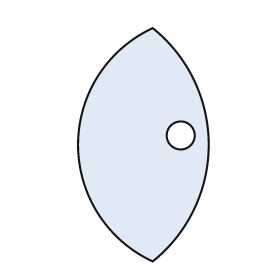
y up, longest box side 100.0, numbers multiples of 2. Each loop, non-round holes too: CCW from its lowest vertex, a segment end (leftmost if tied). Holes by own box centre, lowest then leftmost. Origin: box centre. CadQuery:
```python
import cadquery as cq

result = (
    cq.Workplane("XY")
    .moveTo(4.0, -50.0)
    .threePointArc((28.0, 0.0), (4.0, 50.0))
    .threePointArc((-28.0, 0.0), (4.0, -50.0))
    .close()
    .moveTo(16.0, 4.0)
    .circle(6.0)
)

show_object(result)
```